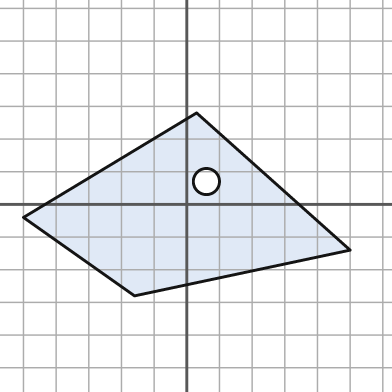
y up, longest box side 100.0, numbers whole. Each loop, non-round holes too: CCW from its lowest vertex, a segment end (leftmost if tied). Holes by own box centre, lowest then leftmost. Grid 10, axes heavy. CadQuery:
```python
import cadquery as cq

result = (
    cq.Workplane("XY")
    .moveTo(-16.0, -28.0)
    .lineTo(50.0, -14.0)
    .lineTo(3.0, 28.0)
    .lineTo(-50.0, -4.0)
    .close()
    .moveTo(6.0, 7.0)
    .circle(4.0)
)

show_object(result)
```